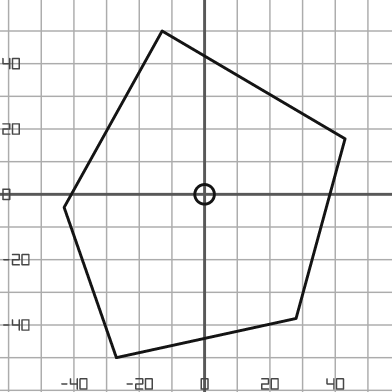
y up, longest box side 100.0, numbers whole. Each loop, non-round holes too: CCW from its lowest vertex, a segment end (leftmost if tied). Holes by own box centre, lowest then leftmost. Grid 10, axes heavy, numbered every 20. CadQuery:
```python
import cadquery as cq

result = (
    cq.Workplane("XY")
    .moveTo(-27.0, -50.0)
    .lineTo(28.0, -38.0)
    .lineTo(43.0, 17.0)
    .lineTo(-13.0, 50.0)
    .lineTo(-43.0, -4.0)
    .close()
    .moveTo(0.0, 0.0)
    .circle(3.0)
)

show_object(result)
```